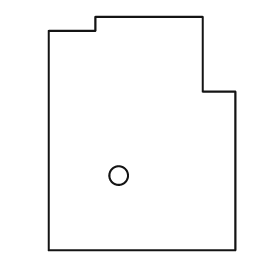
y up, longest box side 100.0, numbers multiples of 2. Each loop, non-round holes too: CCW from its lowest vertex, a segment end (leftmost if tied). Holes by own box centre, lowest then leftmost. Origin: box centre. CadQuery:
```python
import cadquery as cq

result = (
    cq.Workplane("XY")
    .moveTo(-40.0, -50.0)
    .lineTo(40.0, -50.0)
    .lineTo(40.0, 18.0)
    .lineTo(26.0, 18.0)
    .lineTo(26.0, 50.0)
    .lineTo(-20.0, 50.0)
    .lineTo(-20.0, 44.0)
    .lineTo(-40.0, 44.0)
    .close()
    .moveTo(-10.0, -18.0)
    .circle(4.0)
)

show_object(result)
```